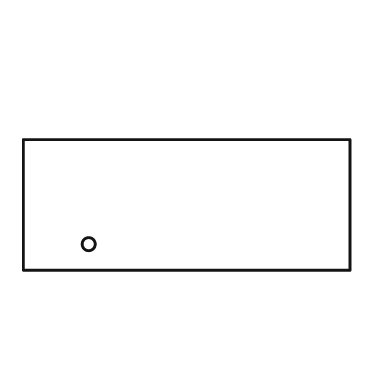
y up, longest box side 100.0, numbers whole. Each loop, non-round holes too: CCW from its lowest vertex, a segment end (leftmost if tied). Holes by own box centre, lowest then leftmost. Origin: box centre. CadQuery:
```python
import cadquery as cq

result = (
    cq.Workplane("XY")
    .moveTo(-50.0, -20.0)
    .lineTo(50.0, -20.0)
    .lineTo(50.0, 20.0)
    .lineTo(-50.0, 20.0)
    .close()
    .moveTo(-30.0, -12.0)
    .circle(2.0)
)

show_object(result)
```